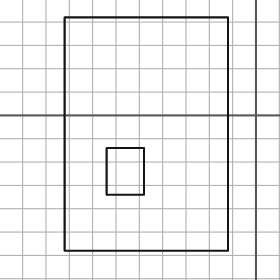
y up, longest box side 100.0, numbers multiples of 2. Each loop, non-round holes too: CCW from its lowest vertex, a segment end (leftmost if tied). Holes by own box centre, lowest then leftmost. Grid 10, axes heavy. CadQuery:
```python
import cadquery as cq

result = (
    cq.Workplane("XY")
    .moveTo(-82.0, -58.0)
    .lineTo(-12.0, -58.0)
    .lineTo(-12.0, 42.0)
    .lineTo(-82.0, 42.0)
    .close()
    .moveTo(-64.0, -34.0)
    .lineTo(-48.0, -34.0)
    .lineTo(-48.0, -14.0)
    .lineTo(-64.0, -14.0)
    .close()
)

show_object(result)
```